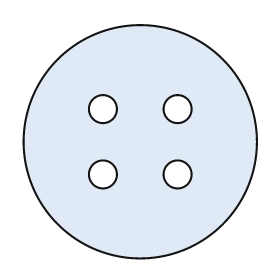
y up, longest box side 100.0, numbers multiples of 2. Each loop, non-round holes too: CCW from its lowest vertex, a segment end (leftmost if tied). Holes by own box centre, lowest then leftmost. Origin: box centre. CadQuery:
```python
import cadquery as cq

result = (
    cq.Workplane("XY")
    .moveTo(0.0, 0.0)
    .circle(50.0)
    .moveTo(-16.0, -14.0)
    .circle(6.0)
    .moveTo(16.0, -14.0)
    .circle(6.0)
    .moveTo(-16.0, 14.0)
    .circle(6.0)
    .moveTo(16.0, 14.0)
    .circle(6.0)
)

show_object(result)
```